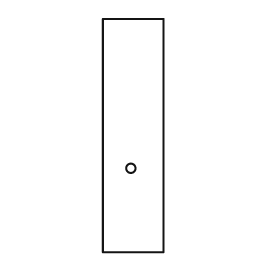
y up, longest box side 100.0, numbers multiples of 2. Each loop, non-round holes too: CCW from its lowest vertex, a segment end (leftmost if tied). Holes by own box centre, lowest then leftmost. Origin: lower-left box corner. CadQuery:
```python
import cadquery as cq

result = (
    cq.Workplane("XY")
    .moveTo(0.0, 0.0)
    .lineTo(26.0, 0.0)
    .lineTo(26.0, 100.0)
    .lineTo(0.0, 100.0)
    .close()
    .moveTo(12.0, 36.0)
    .circle(2.0)
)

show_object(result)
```